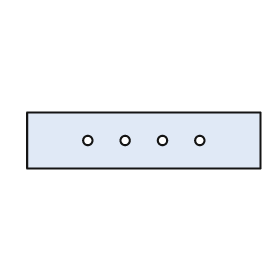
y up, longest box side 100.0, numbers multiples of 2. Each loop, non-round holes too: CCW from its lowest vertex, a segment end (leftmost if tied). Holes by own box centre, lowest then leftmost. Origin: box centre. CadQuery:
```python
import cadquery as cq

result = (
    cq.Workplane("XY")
    .moveTo(-50.0, -12.0)
    .lineTo(50.0, -12.0)
    .lineTo(50.0, 12.0)
    .lineTo(-50.0, 12.0)
    .close()
    .moveTo(-24.0, 0.0)
    .circle(2.0)
    .moveTo(-8.0, 0.0)
    .circle(2.0)
    .moveTo(8.0, 0.0)
    .circle(2.0)
    .moveTo(24.0, 0.0)
    .circle(2.0)
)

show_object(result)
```